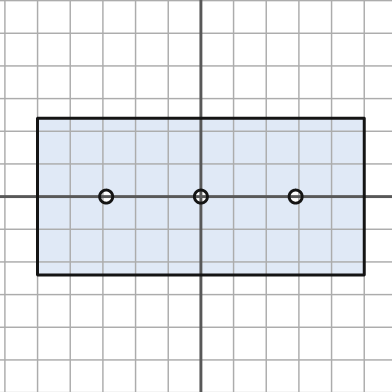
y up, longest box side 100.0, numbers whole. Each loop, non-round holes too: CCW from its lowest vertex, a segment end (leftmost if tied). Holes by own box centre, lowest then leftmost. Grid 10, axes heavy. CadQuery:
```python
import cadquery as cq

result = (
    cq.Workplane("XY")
    .moveTo(-50.0, -24.0)
    .lineTo(50.0, -24.0)
    .lineTo(50.0, 24.0)
    .lineTo(-50.0, 24.0)
    .close()
    .moveTo(-29.0, 0.0)
    .circle(2.0)
    .moveTo(0.0, 0.0)
    .circle(2.0)
    .moveTo(29.0, 0.0)
    .circle(2.0)
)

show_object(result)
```